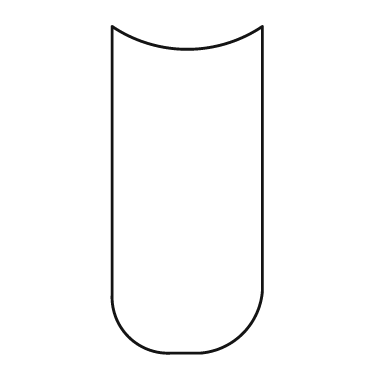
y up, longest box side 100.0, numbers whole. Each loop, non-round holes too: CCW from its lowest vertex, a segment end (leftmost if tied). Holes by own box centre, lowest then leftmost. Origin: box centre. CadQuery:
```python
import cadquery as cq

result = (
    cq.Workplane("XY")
    .moveTo(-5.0, -50.0)
    .lineTo(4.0, -50.0)
    .threePointArc((17.0, -44.0), (23.0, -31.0))
    .lineTo(23.0, 50.0)
    .threePointArc((0.0, 43.0), (-23.0, 50.0))
    .lineTo(-23.0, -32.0)
    .threePointArc((-18.0, -45.0), (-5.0, -50.0))
    .close()
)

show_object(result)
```